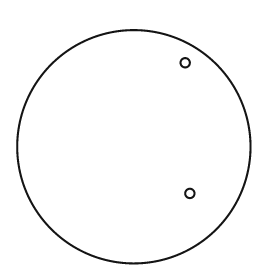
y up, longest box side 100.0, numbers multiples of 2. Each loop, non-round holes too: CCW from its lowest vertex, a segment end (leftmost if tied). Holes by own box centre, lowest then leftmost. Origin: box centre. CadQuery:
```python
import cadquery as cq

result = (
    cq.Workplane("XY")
    .moveTo(0.0, 0.0)
    .circle(50.0)
    .moveTo(24.0, -20.0)
    .circle(2.0)
    .moveTo(22.0, 36.0)
    .circle(2.0)
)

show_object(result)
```